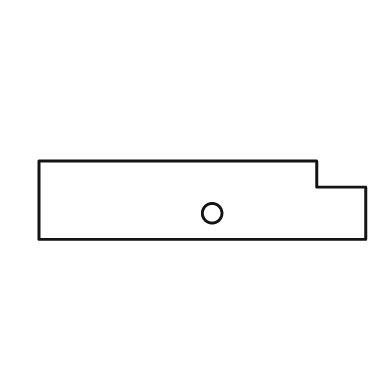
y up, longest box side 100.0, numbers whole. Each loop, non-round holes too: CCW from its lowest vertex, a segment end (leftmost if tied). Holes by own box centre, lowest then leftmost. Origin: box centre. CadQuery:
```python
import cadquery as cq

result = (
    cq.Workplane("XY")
    .moveTo(-50.0, -12.0)
    .lineTo(50.0, -12.0)
    .lineTo(50.0, 4.0)
    .lineTo(35.0, 4.0)
    .lineTo(35.0, 12.0)
    .lineTo(-50.0, 12.0)
    .close()
    .moveTo(3.0, -4.0)
    .circle(3.0)
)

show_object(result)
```